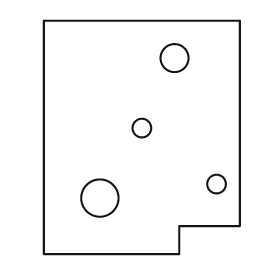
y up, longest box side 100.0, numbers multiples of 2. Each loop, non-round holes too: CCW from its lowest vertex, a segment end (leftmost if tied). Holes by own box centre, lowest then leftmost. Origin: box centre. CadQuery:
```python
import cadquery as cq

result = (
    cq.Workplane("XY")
    .moveTo(-42.0, -50.0)
    .lineTo(16.0, -50.0)
    .lineTo(16.0, -38.0)
    .lineTo(42.0, -38.0)
    .lineTo(42.0, 50.0)
    .lineTo(-42.0, 50.0)
    .close()
    .moveTo(-18.0, -26.0)
    .circle(8.0)
    .moveTo(32.0, -20.0)
    .circle(4.0)
    .moveTo(0.0, 4.0)
    .circle(4.0)
    .moveTo(14.0, 34.0)
    .circle(6.0)
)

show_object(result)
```